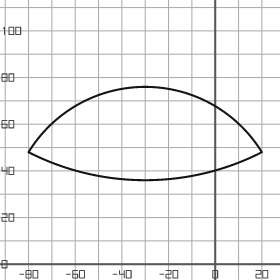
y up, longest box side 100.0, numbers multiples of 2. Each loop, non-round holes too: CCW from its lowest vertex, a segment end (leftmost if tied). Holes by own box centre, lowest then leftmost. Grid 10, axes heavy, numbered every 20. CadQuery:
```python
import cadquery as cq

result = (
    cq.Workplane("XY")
    .moveTo(-80.0, 48.0)
    .threePointArc((-30.0, 36.0), (20.0, 48.0))
    .threePointArc((-30.0, 76.0), (-80.0, 48.0))
    .close()
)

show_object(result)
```